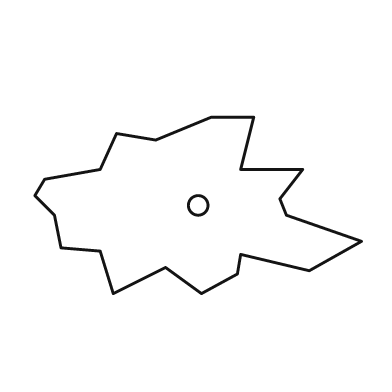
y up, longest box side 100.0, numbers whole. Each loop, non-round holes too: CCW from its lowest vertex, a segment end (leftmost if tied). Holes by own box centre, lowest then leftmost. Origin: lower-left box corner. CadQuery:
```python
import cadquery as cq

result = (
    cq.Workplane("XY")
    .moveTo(24.0, 0.0)
    .lineTo(40.0, 8.0)
    .lineTo(51.0, 0.0)
    .lineTo(62.0, 6.0)
    .lineTo(63.0, 12.0)
    .lineTo(84.0, 7.0)
    .lineTo(100.0, 16.0)
    .lineTo(77.0, 24.0)
    .lineTo(75.0, 29.0)
    .lineTo(82.0, 38.0)
    .lineTo(63.0, 38.0)
    .lineTo(67.0, 54.0)
    .lineTo(54.0, 54.0)
    .lineTo(37.0, 47.0)
    .lineTo(25.0, 49.0)
    .lineTo(20.0, 38.0)
    .lineTo(3.0, 35.0)
    .lineTo(0.0, 30.0)
    .lineTo(6.0, 24.0)
    .lineTo(8.0, 14.0)
    .lineTo(20.0, 13.0)
    .close()
    .moveTo(50.0, 27.0)
    .circle(3.0)
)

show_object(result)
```